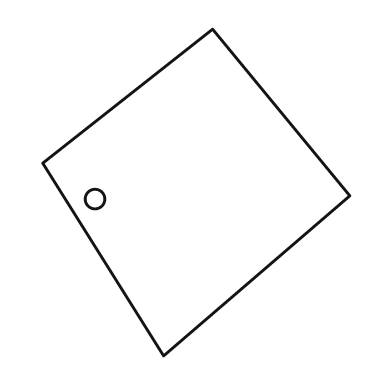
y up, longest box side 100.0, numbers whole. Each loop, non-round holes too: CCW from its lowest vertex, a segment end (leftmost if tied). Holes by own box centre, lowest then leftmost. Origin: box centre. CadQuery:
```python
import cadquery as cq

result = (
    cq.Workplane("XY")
    .moveTo(-10.0, -50.0)
    .lineTo(47.0, -1.0)
    .lineTo(5.0, 50.0)
    .lineTo(-47.0, 9.0)
    .close()
    .moveTo(-31.0, -2.0)
    .circle(3.0)
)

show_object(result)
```